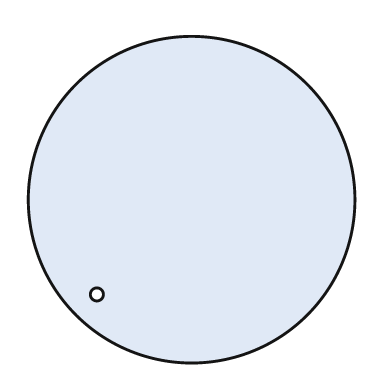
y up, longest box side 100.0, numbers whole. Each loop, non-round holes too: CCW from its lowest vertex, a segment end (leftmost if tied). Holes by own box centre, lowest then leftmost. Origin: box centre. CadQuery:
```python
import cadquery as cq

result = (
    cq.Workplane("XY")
    .moveTo(0.0, 0.0)
    .circle(50.0)
    .moveTo(-29.0, -29.0)
    .circle(2.0)
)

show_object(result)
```